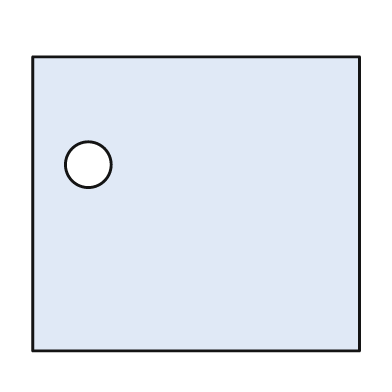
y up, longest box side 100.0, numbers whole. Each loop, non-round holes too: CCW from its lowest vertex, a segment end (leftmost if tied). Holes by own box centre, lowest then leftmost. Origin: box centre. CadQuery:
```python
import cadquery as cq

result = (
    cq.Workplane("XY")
    .moveTo(-50.0, -45.0)
    .lineTo(50.0, -45.0)
    .lineTo(50.0, 45.0)
    .lineTo(-50.0, 45.0)
    .close()
    .moveTo(-33.0, 12.0)
    .circle(7.0)
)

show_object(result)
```